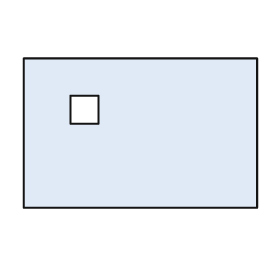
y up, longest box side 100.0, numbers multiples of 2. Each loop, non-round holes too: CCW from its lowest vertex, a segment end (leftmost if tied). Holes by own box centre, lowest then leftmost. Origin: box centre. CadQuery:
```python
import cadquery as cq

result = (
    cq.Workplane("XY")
    .moveTo(-50.0, -32.0)
    .lineTo(50.0, -32.0)
    .lineTo(50.0, 32.0)
    .lineTo(-50.0, 32.0)
    .close()
    .moveTo(-30.0, 4.0)
    .lineTo(-18.0, 4.0)
    .lineTo(-18.0, 16.0)
    .lineTo(-30.0, 16.0)
    .close()
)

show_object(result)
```